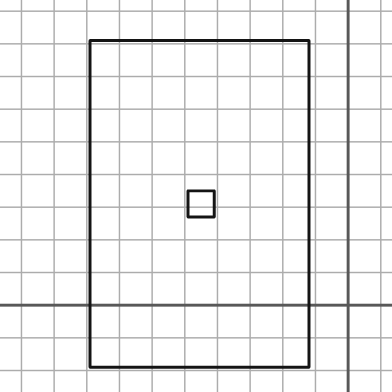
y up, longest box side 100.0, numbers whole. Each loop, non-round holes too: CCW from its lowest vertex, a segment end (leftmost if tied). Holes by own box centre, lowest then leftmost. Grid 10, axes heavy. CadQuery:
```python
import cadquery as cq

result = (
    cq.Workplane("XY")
    .moveTo(-79.0, -19.0)
    .lineTo(-12.0, -19.0)
    .lineTo(-12.0, 81.0)
    .lineTo(-79.0, 81.0)
    .close()
    .moveTo(-49.0, 27.0)
    .lineTo(-41.0, 27.0)
    .lineTo(-41.0, 35.0)
    .lineTo(-49.0, 35.0)
    .close()
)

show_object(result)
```